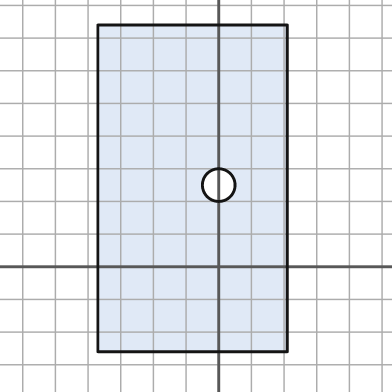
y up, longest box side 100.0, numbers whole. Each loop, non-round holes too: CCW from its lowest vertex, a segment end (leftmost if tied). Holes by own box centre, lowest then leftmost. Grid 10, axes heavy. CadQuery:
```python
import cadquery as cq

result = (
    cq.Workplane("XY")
    .moveTo(-37.0, -26.0)
    .lineTo(21.0, -26.0)
    .lineTo(21.0, 74.0)
    .lineTo(-37.0, 74.0)
    .close()
    .moveTo(0.0, 25.0)
    .circle(5.0)
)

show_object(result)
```